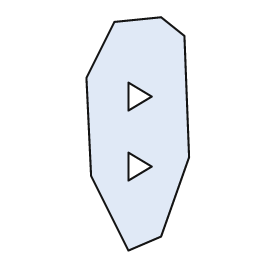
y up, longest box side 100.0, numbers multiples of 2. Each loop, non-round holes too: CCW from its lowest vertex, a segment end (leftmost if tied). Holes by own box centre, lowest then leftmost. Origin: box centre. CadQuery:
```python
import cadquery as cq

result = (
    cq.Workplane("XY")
    .moveTo(-4.0, -50.0)
    .lineTo(10.0, -44.0)
    .lineTo(22.0, -10.0)
    .lineTo(20.0, 42.0)
    .lineTo(10.0, 50.0)
    .lineTo(-10.0, 48.0)
    .lineTo(-22.0, 24.0)
    .lineTo(-20.0, -18.0)
    .close()
    .moveTo(-4.0, -20.0)
    .lineTo(6.0, -14.0)
    .lineTo(-4.0, -8.0)
    .close()
    .moveTo(-4.0, 10.0)
    .lineTo(6.0, 16.0)
    .lineTo(-4.0, 22.0)
    .close()
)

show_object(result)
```